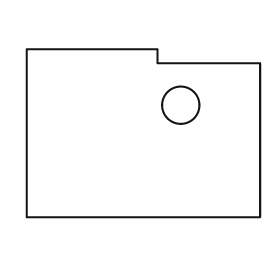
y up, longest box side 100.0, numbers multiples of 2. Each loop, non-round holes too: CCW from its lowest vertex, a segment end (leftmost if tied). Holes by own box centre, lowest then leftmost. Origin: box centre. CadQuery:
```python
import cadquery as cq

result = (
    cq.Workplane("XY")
    .moveTo(-50.0, -36.0)
    .lineTo(50.0, -36.0)
    .lineTo(50.0, 30.0)
    .lineTo(6.0, 30.0)
    .lineTo(6.0, 36.0)
    .lineTo(-50.0, 36.0)
    .close()
    .moveTo(16.0, 12.0)
    .circle(8.0)
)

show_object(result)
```